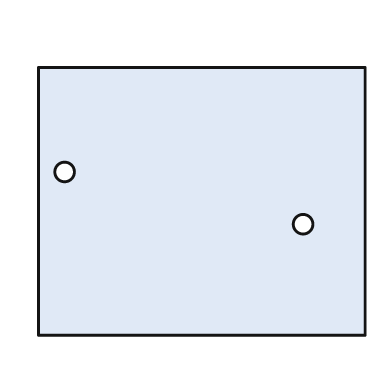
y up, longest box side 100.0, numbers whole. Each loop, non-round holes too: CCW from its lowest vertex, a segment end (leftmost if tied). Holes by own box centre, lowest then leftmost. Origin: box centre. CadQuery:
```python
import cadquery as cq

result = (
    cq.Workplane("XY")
    .moveTo(-50.0, -41.0)
    .lineTo(50.0, -41.0)
    .lineTo(50.0, 41.0)
    .lineTo(-50.0, 41.0)
    .close()
    .moveTo(31.0, -7.0)
    .circle(3.0)
    .moveTo(-42.0, 9.0)
    .circle(3.0)
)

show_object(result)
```